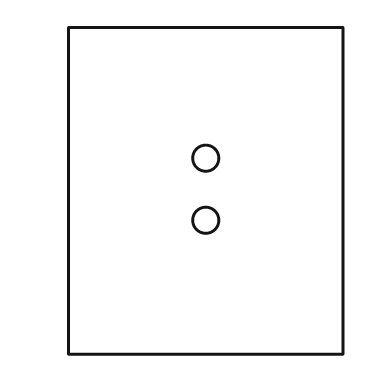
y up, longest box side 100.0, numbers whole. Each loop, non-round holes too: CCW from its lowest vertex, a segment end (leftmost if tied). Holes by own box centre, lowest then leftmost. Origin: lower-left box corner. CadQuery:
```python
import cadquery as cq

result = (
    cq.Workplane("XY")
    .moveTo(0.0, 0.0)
    .lineTo(84.0, 0.0)
    .lineTo(84.0, 100.0)
    .lineTo(0.0, 100.0)
    .close()
    .moveTo(42.0, 41.0)
    .circle(4.0)
    .moveTo(42.0, 60.0)
    .circle(4.0)
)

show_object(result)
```